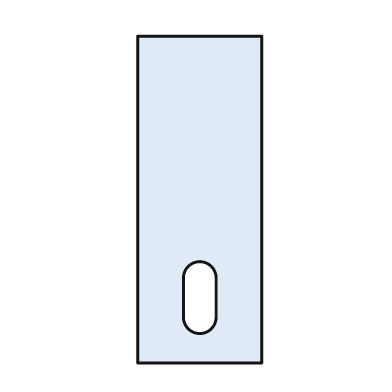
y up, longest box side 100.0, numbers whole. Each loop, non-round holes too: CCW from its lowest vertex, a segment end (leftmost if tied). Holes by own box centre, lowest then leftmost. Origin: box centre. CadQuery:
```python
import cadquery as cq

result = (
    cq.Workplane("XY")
    .moveTo(-19.0, -50.0)
    .lineTo(19.0, -50.0)
    .lineTo(19.0, 50.0)
    .lineTo(-19.0, 50.0)
    .close()
    .moveTo(-5.0, -36.0)
    .threePointArc((0.0, -41.0), (5.0, -36.0))
    .lineTo(5.0, -24.0)
    .threePointArc((0.0, -19.0), (-5.0, -24.0))
    .close()
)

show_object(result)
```